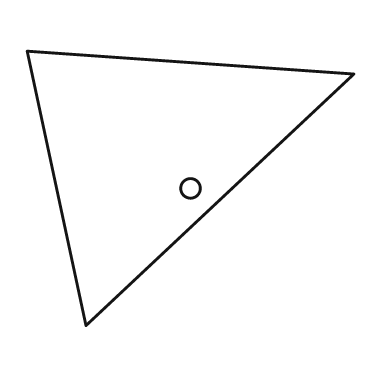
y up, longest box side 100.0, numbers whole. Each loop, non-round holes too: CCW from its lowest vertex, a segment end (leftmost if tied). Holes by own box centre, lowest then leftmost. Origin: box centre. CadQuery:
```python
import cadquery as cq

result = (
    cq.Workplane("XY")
    .moveTo(-32.0, -42.0)
    .lineTo(50.0, 35.0)
    .lineTo(-50.0, 42.0)
    .close()
    .moveTo(0.0, 0.0)
    .circle(3.0)
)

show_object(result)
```